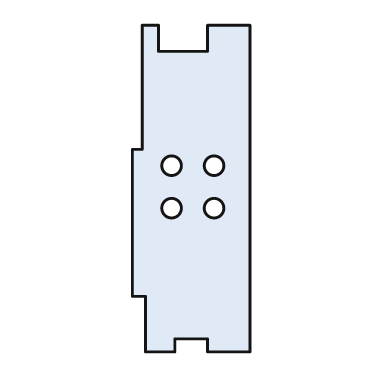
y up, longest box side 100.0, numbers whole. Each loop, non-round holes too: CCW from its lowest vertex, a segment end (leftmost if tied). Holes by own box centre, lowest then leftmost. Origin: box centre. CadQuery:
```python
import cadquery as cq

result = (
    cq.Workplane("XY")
    .moveTo(-14.0, -50.0)
    .lineTo(-5.0, -50.0)
    .lineTo(-5.0, -46.0)
    .lineTo(5.0, -46.0)
    .lineTo(5.0, -50.0)
    .lineTo(18.0, -50.0)
    .lineTo(18.0, 50.0)
    .lineTo(5.0, 50.0)
    .lineTo(5.0, 42.0)
    .lineTo(-10.0, 42.0)
    .lineTo(-10.0, 50.0)
    .lineTo(-15.0, 50.0)
    .lineTo(-15.0, 12.0)
    .lineTo(-18.0, 12.0)
    .lineTo(-18.0, -33.0)
    .lineTo(-14.0, -33.0)
    .close()
    .moveTo(-6.0, -6.0)
    .circle(3.0)
    .moveTo(7.0, -6.0)
    .circle(3.0)
    .moveTo(-6.0, 7.0)
    .circle(3.0)
    .moveTo(7.0, 7.0)
    .circle(3.0)
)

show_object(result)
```